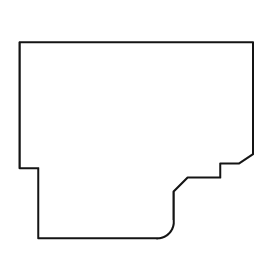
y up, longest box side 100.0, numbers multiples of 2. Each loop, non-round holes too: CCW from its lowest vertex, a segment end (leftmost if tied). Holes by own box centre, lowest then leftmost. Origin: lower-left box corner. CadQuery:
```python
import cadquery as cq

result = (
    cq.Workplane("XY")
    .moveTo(8.0, 0.0)
    .lineTo(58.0, 0.0)
    .threePointArc((64.0, 2.0), (66.0, 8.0))
    .lineTo(66.0, 20.0)
    .lineTo(72.0, 26.0)
    .lineTo(86.0, 26.0)
    .lineTo(86.0, 32.0)
    .lineTo(94.0, 32.0)
    .lineTo(100.0, 36.0)
    .lineTo(100.0, 84.0)
    .lineTo(0.0, 84.0)
    .lineTo(0.0, 30.0)
    .lineTo(8.0, 30.0)
    .close()
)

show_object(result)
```